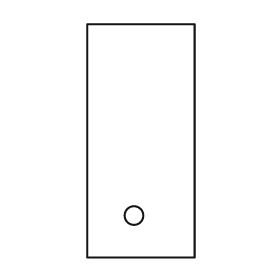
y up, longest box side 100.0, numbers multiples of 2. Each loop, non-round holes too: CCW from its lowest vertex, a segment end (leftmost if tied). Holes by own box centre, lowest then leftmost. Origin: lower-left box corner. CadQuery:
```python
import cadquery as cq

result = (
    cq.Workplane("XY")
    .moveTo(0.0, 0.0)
    .lineTo(46.0, 0.0)
    .lineTo(46.0, 100.0)
    .lineTo(0.0, 100.0)
    .close()
    .moveTo(20.0, 18.0)
    .circle(4.0)
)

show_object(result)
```